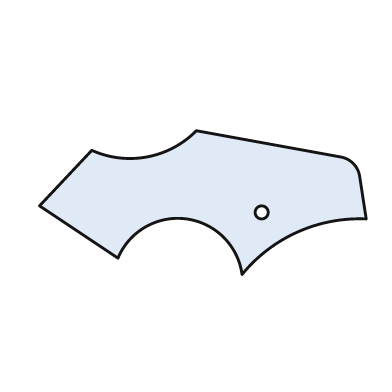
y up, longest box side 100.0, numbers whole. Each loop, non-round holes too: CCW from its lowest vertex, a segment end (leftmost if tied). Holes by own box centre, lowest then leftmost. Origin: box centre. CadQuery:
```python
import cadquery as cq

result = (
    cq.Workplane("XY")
    .moveTo(12.0, -22.0)
    .threePointArc((29.0, -9.0), (50.0, -5.0))
    .lineTo(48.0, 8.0)
    .threePointArc((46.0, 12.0), (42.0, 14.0))
    .lineTo(-2.0, 22.0)
    .threePointArc((-17.0, 14.0), (-34.0, 16.0))
    .lineTo(-50.0, -1.0)
    .lineTo(-26.0, -17.0)
    .threePointArc((-5.0, -5.0), (12.0, -22.0))
    .close()
    .moveTo(18.0, -3.0)
    .circle(2.0)
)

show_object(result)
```